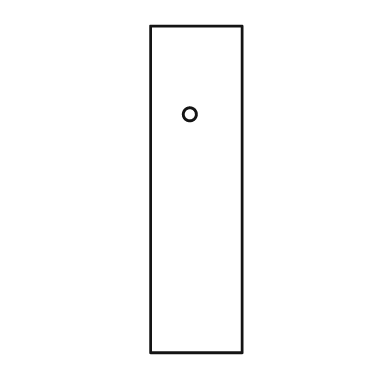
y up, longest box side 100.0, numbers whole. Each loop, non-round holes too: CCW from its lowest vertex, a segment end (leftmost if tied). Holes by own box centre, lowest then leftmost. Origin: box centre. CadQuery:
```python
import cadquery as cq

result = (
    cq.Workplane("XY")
    .moveTo(-14.0, -50.0)
    .lineTo(14.0, -50.0)
    .lineTo(14.0, 50.0)
    .lineTo(-14.0, 50.0)
    .close()
    .moveTo(-2.0, 23.0)
    .circle(2.0)
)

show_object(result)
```